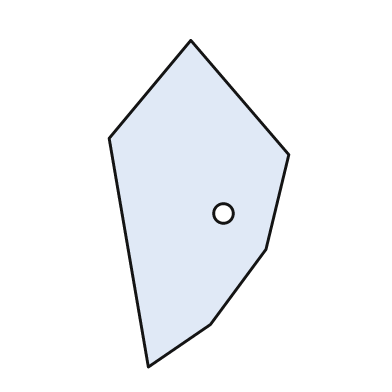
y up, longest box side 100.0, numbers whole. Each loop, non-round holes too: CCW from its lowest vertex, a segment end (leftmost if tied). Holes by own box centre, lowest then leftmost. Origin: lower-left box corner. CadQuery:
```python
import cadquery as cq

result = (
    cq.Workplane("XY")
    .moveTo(12.0, 0.0)
    .lineTo(31.0, 13.0)
    .lineTo(48.0, 36.0)
    .lineTo(55.0, 65.0)
    .lineTo(25.0, 100.0)
    .lineTo(0.0, 70.0)
    .close()
    .moveTo(35.0, 47.0)
    .circle(3.0)
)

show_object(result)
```